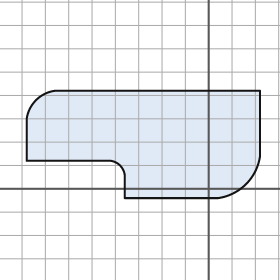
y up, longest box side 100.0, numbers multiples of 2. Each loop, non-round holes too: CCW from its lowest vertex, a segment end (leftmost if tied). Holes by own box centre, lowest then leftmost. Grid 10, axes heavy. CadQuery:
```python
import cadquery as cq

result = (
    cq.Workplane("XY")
    .moveTo(-36.0, -4.0)
    .lineTo(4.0, -4.0)
    .threePointArc((16.0, 2.0), (22.0, 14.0))
    .lineTo(22.0, 42.0)
    .lineTo(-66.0, 42.0)
    .threePointArc((-74.0, 38.0), (-78.0, 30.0))
    .lineTo(-78.0, 12.0)
    .lineTo(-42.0, 12.0)
    .threePointArc((-38.0, 10.0), (-36.0, 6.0))
    .close()
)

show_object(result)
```